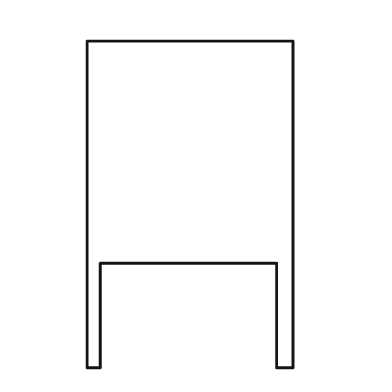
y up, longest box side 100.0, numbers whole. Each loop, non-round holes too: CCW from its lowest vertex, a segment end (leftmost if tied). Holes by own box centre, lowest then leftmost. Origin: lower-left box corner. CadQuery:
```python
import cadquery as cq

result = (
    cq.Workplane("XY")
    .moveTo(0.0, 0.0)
    .lineTo(4.0, 0.0)
    .lineTo(4.0, 32.0)
    .lineTo(58.0, 32.0)
    .lineTo(58.0, 0.0)
    .lineTo(63.0, 0.0)
    .lineTo(63.0, 100.0)
    .lineTo(0.0, 100.0)
    .close()
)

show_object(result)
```